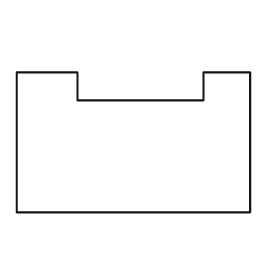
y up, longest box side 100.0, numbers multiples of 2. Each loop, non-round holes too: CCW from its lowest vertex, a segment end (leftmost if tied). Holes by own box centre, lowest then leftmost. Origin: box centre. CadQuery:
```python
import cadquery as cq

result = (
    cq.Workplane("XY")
    .moveTo(-50.0, -30.0)
    .lineTo(50.0, -30.0)
    .lineTo(50.0, 30.0)
    .lineTo(30.0, 30.0)
    .lineTo(30.0, 18.0)
    .lineTo(-24.0, 18.0)
    .lineTo(-24.0, 30.0)
    .lineTo(-50.0, 30.0)
    .close()
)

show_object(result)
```